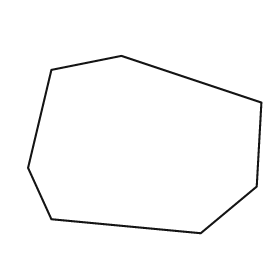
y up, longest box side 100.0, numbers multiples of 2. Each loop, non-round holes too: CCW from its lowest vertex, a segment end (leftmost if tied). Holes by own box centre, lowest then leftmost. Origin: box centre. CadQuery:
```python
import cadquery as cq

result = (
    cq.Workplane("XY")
    .moveTo(24.0, -38.0)
    .lineTo(48.0, -18.0)
    .lineTo(50.0, 18.0)
    .lineTo(-10.0, 38.0)
    .lineTo(-40.0, 32.0)
    .lineTo(-50.0, -10.0)
    .lineTo(-40.0, -32.0)
    .close()
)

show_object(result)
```